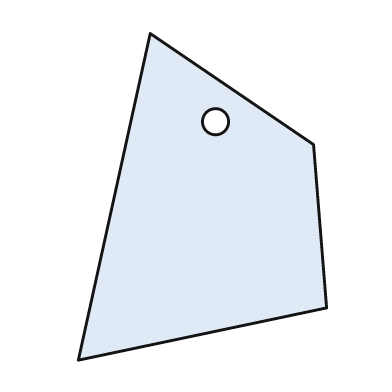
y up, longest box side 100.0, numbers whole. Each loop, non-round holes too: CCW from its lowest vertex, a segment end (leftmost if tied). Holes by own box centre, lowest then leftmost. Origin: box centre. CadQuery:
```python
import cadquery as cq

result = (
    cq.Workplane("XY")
    .moveTo(-38.0, -50.0)
    .lineTo(38.0, -34.0)
    .lineTo(34.0, 16.0)
    .lineTo(-16.0, 50.0)
    .close()
    .moveTo(4.0, 23.0)
    .circle(4.0)
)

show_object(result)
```